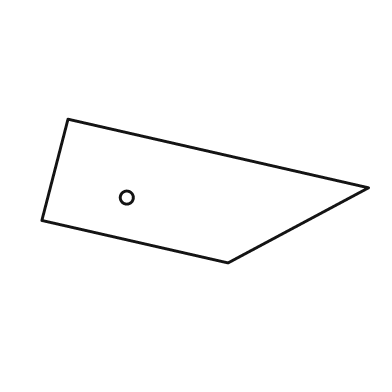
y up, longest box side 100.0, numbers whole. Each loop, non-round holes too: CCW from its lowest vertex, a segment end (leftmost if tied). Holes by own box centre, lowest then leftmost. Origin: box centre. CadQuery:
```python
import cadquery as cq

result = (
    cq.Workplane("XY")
    .moveTo(7.0, -22.0)
    .lineTo(50.0, 1.0)
    .lineTo(-42.0, 22.0)
    .lineTo(-50.0, -9.0)
    .close()
    .moveTo(-24.0, -2.0)
    .circle(2.0)
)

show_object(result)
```